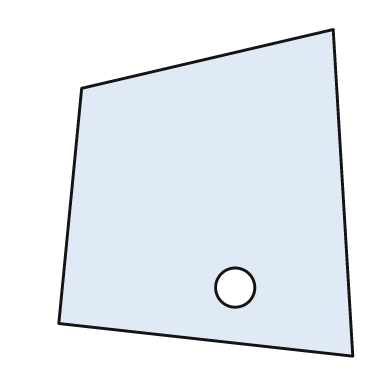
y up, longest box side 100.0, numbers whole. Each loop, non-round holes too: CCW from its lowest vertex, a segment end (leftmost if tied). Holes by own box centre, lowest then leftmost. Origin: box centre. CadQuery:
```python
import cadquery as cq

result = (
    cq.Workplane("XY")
    .moveTo(45.0, -50.0)
    .lineTo(39.0, 50.0)
    .lineTo(-38.0, 32.0)
    .lineTo(-45.0, -40.0)
    .close()
    .moveTo(9.0, -29.0)
    .circle(6.0)
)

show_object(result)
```